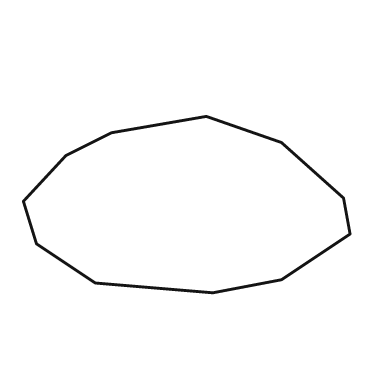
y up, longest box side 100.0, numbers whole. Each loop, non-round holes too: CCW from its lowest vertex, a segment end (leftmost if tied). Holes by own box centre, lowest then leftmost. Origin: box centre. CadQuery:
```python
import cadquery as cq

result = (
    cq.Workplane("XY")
    .moveTo(8.0, -27.0)
    .lineTo(29.0, -23.0)
    .lineTo(50.0, -9.0)
    .lineTo(48.0, 2.0)
    .lineTo(29.0, 19.0)
    .lineTo(6.0, 27.0)
    .lineTo(-23.0, 22.0)
    .lineTo(-37.0, 15.0)
    .lineTo(-50.0, 1.0)
    .lineTo(-46.0, -12.0)
    .lineTo(-28.0, -24.0)
    .close()
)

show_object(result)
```